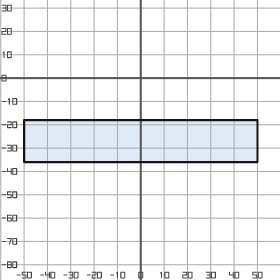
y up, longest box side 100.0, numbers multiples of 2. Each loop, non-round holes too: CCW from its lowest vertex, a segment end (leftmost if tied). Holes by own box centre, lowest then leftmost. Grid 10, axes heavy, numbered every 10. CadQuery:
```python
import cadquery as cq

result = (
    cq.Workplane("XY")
    .moveTo(-50.0, -36.0)
    .lineTo(50.0, -36.0)
    .lineTo(50.0, -18.0)
    .lineTo(-50.0, -18.0)
    .close()
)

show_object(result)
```